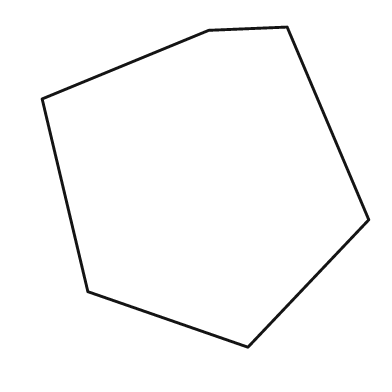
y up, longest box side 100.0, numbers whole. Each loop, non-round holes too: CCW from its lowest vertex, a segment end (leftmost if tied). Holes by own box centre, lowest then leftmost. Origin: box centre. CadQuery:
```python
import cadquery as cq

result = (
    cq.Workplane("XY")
    .moveTo(13.0, -49.0)
    .lineTo(50.0, -10.0)
    .lineTo(25.0, 49.0)
    .lineTo(1.0, 48.0)
    .lineTo(-50.0, 27.0)
    .lineTo(-36.0, -32.0)
    .close()
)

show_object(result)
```